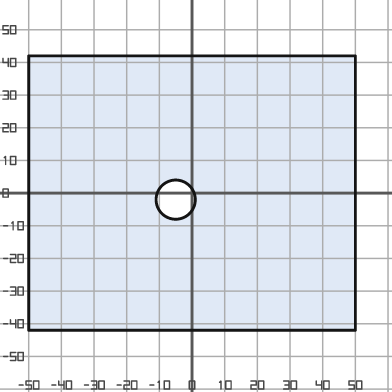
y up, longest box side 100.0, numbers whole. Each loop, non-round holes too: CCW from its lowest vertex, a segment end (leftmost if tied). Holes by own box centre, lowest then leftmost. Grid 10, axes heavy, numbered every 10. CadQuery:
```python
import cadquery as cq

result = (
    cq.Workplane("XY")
    .moveTo(-50.0, -42.0)
    .lineTo(50.0, -42.0)
    .lineTo(50.0, 42.0)
    .lineTo(-50.0, 42.0)
    .close()
    .moveTo(-5.0, -2.0)
    .circle(6.0)
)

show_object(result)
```